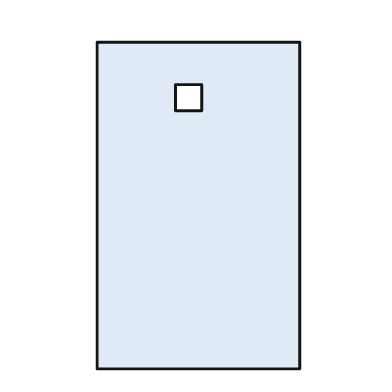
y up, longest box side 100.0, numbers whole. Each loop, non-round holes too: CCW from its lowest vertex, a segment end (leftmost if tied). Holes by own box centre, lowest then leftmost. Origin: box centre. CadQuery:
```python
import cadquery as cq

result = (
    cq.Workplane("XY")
    .moveTo(-31.0, -50.0)
    .lineTo(31.0, -50.0)
    .lineTo(31.0, 50.0)
    .lineTo(-31.0, 50.0)
    .close()
    .moveTo(-7.0, 29.0)
    .lineTo(1.0, 29.0)
    .lineTo(1.0, 37.0)
    .lineTo(-7.0, 37.0)
    .close()
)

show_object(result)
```